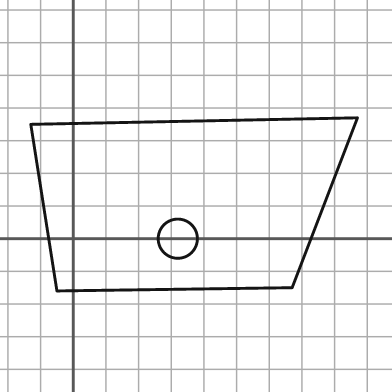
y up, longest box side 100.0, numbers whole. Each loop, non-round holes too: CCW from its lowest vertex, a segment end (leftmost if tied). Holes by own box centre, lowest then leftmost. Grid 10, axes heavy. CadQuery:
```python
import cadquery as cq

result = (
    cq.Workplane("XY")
    .moveTo(-5.0, -16.0)
    .lineTo(67.0, -15.0)
    .lineTo(87.0, 37.0)
    .lineTo(-13.0, 35.0)
    .close()
    .moveTo(32.0, 0.0)
    .circle(6.0)
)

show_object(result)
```